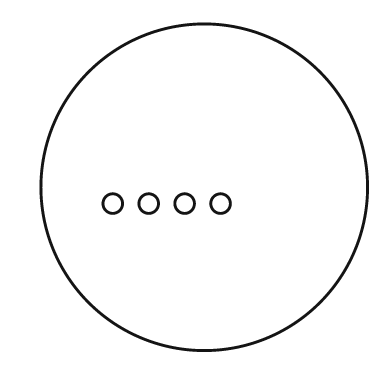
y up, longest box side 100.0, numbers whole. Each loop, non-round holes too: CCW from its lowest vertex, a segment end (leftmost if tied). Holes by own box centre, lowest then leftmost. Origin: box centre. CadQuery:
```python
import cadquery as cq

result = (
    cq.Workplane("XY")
    .moveTo(0.0, 0.0)
    .circle(50.0)
    .moveTo(-28.0, -5.0)
    .circle(3.0)
    .moveTo(-17.0, -5.0)
    .circle(3.0)
    .moveTo(-6.0, -5.0)
    .circle(3.0)
    .moveTo(5.0, -5.0)
    .circle(3.0)
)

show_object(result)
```